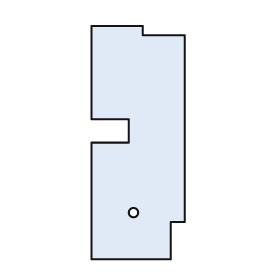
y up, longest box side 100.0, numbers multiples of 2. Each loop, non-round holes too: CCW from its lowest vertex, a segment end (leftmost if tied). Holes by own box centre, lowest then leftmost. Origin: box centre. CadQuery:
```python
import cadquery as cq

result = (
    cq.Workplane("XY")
    .moveTo(-20.0, -50.0)
    .lineTo(14.0, -50.0)
    .lineTo(14.0, -34.0)
    .lineTo(20.0, -34.0)
    .lineTo(20.0, 46.0)
    .lineTo(2.0, 46.0)
    .lineTo(2.0, 50.0)
    .lineTo(-20.0, 50.0)
    .lineTo(-20.0, 10.0)
    .lineTo(-4.0, 10.0)
    .lineTo(-4.0, 0.0)
    .lineTo(-20.0, 0.0)
    .close()
    .moveTo(-2.0, -30.0)
    .circle(2.0)
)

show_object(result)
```